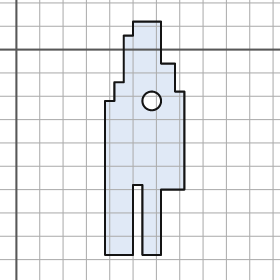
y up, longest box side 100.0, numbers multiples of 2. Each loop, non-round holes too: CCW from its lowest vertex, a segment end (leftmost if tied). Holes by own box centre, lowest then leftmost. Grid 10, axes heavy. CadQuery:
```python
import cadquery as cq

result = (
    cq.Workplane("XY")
    .moveTo(38.0, -88.0)
    .lineTo(50.0, -88.0)
    .lineTo(50.0, -58.0)
    .lineTo(54.0, -58.0)
    .lineTo(54.0, -88.0)
    .lineTo(62.0, -88.0)
    .lineTo(62.0, -60.0)
    .lineTo(72.0, -60.0)
    .lineTo(72.0, -18.0)
    .lineTo(68.0, -18.0)
    .lineTo(68.0, -6.0)
    .lineTo(62.0, -6.0)
    .lineTo(62.0, 12.0)
    .lineTo(50.0, 12.0)
    .lineTo(50.0, 6.0)
    .lineTo(46.0, 6.0)
    .lineTo(46.0, -14.0)
    .lineTo(42.0, -14.0)
    .lineTo(42.0, -22.0)
    .lineTo(38.0, -22.0)
    .close()
    .moveTo(58.0, -22.0)
    .circle(4.0)
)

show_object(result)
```